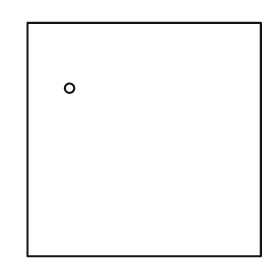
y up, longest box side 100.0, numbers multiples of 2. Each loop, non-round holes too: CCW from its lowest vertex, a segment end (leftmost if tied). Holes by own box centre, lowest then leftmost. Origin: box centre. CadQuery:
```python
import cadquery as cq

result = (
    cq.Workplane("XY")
    .moveTo(-50.0, -50.0)
    .lineTo(50.0, -50.0)
    .lineTo(50.0, 50.0)
    .lineTo(-50.0, 50.0)
    .close()
    .moveTo(-32.0, 22.0)
    .circle(2.0)
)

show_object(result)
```